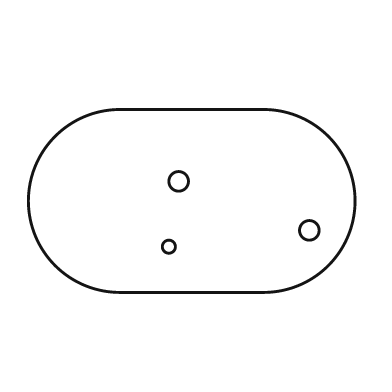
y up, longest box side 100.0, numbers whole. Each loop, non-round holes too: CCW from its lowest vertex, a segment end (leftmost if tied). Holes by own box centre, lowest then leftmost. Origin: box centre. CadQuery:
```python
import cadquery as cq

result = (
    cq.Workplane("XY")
    .moveTo(-22.0, -28.0)
    .lineTo(22.0, -28.0)
    .threePointArc((50.0, 0.0), (22.0, 28.0))
    .lineTo(-22.0, 28.0)
    .threePointArc((-50.0, 0.0), (-22.0, -28.0))
    .close()
    .moveTo(-7.0, -14.0)
    .circle(2.0)
    .moveTo(36.0, -9.0)
    .circle(3.0)
    .moveTo(-4.0, 6.0)
    .circle(3.0)
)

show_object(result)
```